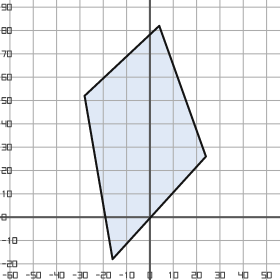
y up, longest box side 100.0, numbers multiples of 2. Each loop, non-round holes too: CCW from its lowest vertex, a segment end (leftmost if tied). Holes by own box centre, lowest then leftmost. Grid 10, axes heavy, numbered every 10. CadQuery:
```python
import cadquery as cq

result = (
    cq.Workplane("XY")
    .moveTo(-16.0, -18.0)
    .lineTo(24.0, 26.0)
    .lineTo(4.0, 82.0)
    .lineTo(-28.0, 52.0)
    .close()
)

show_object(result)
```